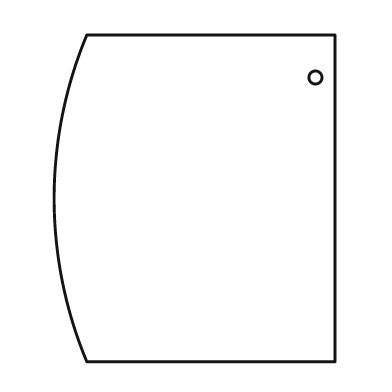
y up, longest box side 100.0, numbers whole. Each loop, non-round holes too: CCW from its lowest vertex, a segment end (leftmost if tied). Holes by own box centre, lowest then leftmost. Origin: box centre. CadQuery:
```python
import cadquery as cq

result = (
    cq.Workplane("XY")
    .moveTo(-33.0, -50.0)
    .lineTo(43.0, -50.0)
    .lineTo(43.0, 50.0)
    .lineTo(-33.0, 50.0)
    .threePointArc((-43.0, 0.0), (-33.0, -50.0))
    .close()
    .moveTo(37.0, 37.0)
    .circle(2.0)
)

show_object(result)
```